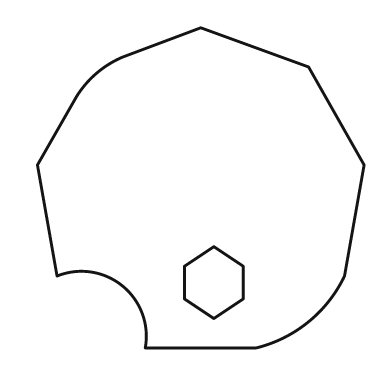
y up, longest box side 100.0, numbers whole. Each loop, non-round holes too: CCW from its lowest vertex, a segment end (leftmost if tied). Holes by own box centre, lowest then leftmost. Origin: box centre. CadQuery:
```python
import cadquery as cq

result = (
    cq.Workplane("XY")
    .moveTo(-17.0, -49.0)
    .lineTo(17.0, -49.0)
    .threePointArc((33.0, -41.0), (44.0, -27.0))
    .lineTo(50.0, 7.0)
    .lineTo(33.0, 37.0)
    .lineTo(0.0, 49.0)
    .lineTo(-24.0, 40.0)
    .threePointArc((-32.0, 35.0), (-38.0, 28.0))
    .lineTo(-50.0, 7.0)
    .lineTo(-44.0, -27.0)
    .threePointArc((-24.0, -30.0), (-17.0, -49.0))
    .close()
    .moveTo(4.0, -40.0)
    .lineTo(13.0, -34.0)
    .lineTo(13.0, -24.0)
    .lineTo(4.0, -18.0)
    .lineTo(-5.0, -24.0)
    .lineTo(-5.0, -34.0)
    .close()
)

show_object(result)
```